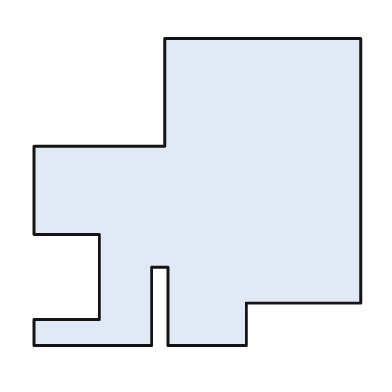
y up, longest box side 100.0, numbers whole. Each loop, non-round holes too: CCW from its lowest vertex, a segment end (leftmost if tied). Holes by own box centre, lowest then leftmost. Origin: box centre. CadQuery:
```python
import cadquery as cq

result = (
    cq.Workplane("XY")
    .moveTo(-50.0, -47.0)
    .lineTo(-14.0, -47.0)
    .lineTo(-14.0, -23.0)
    .lineTo(-9.0, -23.0)
    .lineTo(-9.0, -47.0)
    .lineTo(15.0, -47.0)
    .lineTo(15.0, -34.0)
    .lineTo(50.0, -34.0)
    .lineTo(50.0, 47.0)
    .lineTo(-10.0, 47.0)
    .lineTo(-10.0, 14.0)
    .lineTo(-50.0, 14.0)
    .lineTo(-50.0, -13.0)
    .lineTo(-30.0, -13.0)
    .lineTo(-30.0, -39.0)
    .lineTo(-50.0, -39.0)
    .close()
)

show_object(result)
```